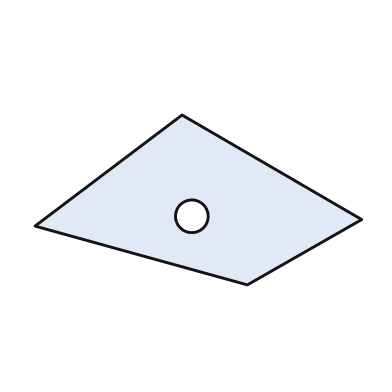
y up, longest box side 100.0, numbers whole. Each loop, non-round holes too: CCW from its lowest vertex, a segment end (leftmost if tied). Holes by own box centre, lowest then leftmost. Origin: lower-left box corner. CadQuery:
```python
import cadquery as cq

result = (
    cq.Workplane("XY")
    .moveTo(65.0, 0.0)
    .lineTo(100.0, 20.0)
    .lineTo(45.0, 52.0)
    .lineTo(0.0, 18.0)
    .close()
    .moveTo(48.0, 21.0)
    .circle(5.0)
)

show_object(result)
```